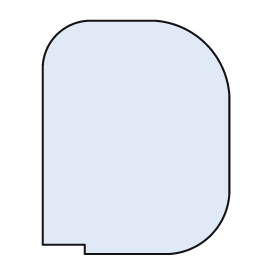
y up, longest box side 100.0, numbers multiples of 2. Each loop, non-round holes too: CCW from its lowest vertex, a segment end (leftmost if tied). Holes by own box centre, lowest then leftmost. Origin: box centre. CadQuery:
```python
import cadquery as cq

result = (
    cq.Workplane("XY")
    .moveTo(-22.0, -50.0)
    .lineTo(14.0, -50.0)
    .threePointArc((32.0, -42.0), (40.0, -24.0))
    .lineTo(40.0, 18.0)
    .threePointArc((30.0, 40.0), (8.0, 50.0))
    .lineTo(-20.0, 50.0)
    .threePointArc((-34.0, 44.0), (-40.0, 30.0))
    .lineTo(-40.0, -46.0)
    .lineTo(-22.0, -46.0)
    .close()
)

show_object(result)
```